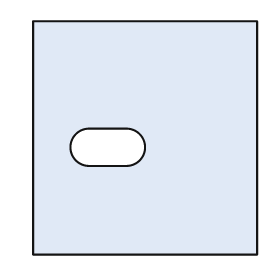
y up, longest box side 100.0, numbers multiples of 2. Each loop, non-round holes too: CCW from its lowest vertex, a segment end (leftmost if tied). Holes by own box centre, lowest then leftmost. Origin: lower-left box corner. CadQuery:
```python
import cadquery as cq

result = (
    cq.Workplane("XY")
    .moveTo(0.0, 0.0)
    .lineTo(96.0, 0.0)
    .lineTo(96.0, 100.0)
    .lineTo(0.0, 100.0)
    .close()
    .moveTo(24.0, 38.0)
    .lineTo(40.0, 38.0)
    .threePointArc((48.0, 46.0), (40.0, 54.0))
    .lineTo(24.0, 54.0)
    .threePointArc((16.0, 46.0), (24.0, 38.0))
    .close()
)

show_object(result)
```